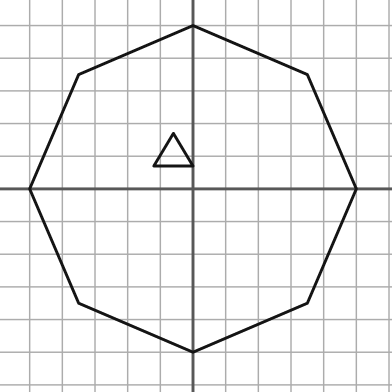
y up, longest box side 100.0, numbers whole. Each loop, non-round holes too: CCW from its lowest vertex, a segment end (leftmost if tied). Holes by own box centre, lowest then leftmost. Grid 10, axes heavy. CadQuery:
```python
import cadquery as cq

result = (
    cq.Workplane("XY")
    .moveTo(0.0, -50.0)
    .lineTo(35.0, -35.0)
    .lineTo(50.0, 0.0)
    .lineTo(35.0, 35.0)
    .lineTo(0.0, 50.0)
    .lineTo(-35.0, 35.0)
    .lineTo(-50.0, 0.0)
    .lineTo(-35.0, -35.0)
    .close()
    .moveTo(-12.0, 7.0)
    .lineTo(0.0, 7.0)
    .lineTo(-6.0, 17.0)
    .close()
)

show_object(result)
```